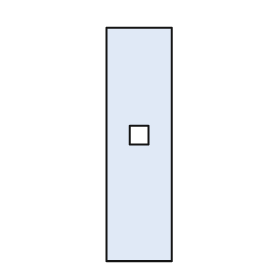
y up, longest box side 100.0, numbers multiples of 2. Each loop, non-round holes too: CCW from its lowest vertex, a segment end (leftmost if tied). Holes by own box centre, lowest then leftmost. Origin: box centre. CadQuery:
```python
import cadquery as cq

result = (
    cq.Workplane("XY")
    .moveTo(-14.0, -50.0)
    .lineTo(14.0, -50.0)
    .lineTo(14.0, 50.0)
    .lineTo(-14.0, 50.0)
    .close()
    .moveTo(-4.0, 0.0)
    .lineTo(4.0, 0.0)
    .lineTo(4.0, 8.0)
    .lineTo(-4.0, 8.0)
    .close()
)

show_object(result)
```